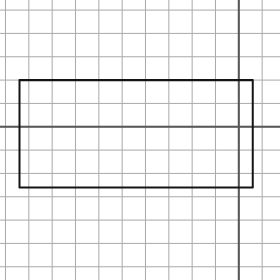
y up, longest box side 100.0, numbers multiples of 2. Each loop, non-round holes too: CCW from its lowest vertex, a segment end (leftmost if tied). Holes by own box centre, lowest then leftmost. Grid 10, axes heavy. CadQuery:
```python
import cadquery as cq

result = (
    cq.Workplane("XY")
    .moveTo(-94.0, -26.0)
    .lineTo(6.0, -26.0)
    .lineTo(6.0, 20.0)
    .lineTo(-94.0, 20.0)
    .close()
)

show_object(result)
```